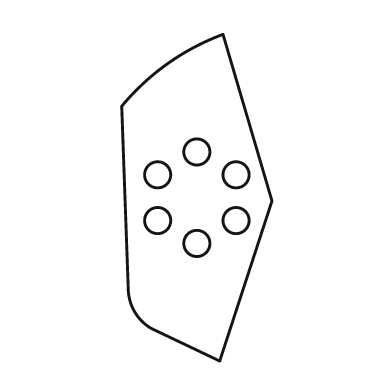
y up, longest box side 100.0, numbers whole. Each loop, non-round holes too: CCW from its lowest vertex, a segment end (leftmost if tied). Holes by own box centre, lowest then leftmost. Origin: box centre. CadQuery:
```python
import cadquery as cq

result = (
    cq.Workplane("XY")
    .moveTo(7.0, -50.0)
    .lineTo(23.0, -1.0)
    .lineTo(8.0, 50.0)
    .threePointArc((-9.0, 41.0), (-23.0, 28.0))
    .lineTo(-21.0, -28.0)
    .threePointArc((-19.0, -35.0), (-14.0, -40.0))
    .close()
    .moveTo(0.0, -14.0)
    .circle(4.0)
    .moveTo(-12.0, -7.0)
    .circle(4.0)
    .moveTo(12.0, -7.0)
    .circle(4.0)
    .moveTo(-12.0, 7.0)
    .circle(4.0)
    .moveTo(12.0, 7.0)
    .circle(4.0)
    .moveTo(0.0, 14.0)
    .circle(4.0)
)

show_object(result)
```